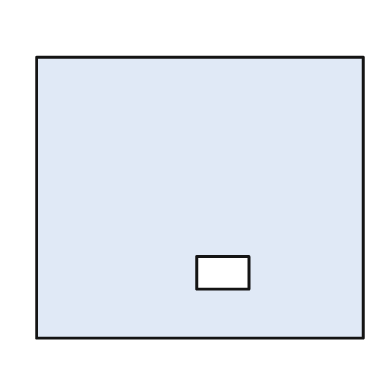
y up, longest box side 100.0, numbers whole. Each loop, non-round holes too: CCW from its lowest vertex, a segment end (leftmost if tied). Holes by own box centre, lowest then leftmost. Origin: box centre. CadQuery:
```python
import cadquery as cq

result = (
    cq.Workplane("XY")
    .moveTo(-50.0, -43.0)
    .lineTo(50.0, -43.0)
    .lineTo(50.0, 43.0)
    .lineTo(-50.0, 43.0)
    .close()
    .moveTo(-1.0, -28.0)
    .lineTo(15.0, -28.0)
    .lineTo(15.0, -18.0)
    .lineTo(-1.0, -18.0)
    .close()
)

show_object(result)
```